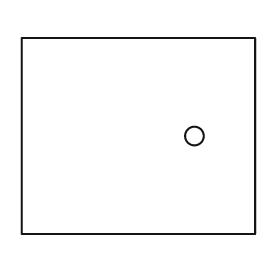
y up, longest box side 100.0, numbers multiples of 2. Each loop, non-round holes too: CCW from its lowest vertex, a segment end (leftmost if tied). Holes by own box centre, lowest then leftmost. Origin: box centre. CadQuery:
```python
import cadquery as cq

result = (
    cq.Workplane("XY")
    .moveTo(-50.0, -42.0)
    .lineTo(50.0, -42.0)
    .lineTo(50.0, 42.0)
    .lineTo(-50.0, 42.0)
    .close()
    .moveTo(24.0, 0.0)
    .circle(4.0)
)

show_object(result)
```